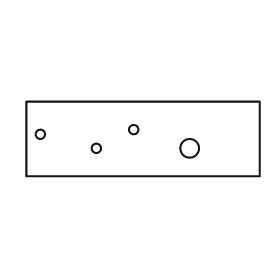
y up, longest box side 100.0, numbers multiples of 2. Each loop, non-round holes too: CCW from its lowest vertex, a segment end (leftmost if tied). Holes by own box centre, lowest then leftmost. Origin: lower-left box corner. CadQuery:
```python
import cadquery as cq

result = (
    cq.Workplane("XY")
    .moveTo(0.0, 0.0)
    .lineTo(100.0, 0.0)
    .lineTo(100.0, 32.0)
    .lineTo(0.0, 32.0)
    .close()
    .moveTo(30.0, 12.0)
    .circle(2.0)
    .moveTo(70.0, 12.0)
    .circle(4.0)
    .moveTo(6.0, 18.0)
    .circle(2.0)
    .moveTo(46.0, 20.0)
    .circle(2.0)
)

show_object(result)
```